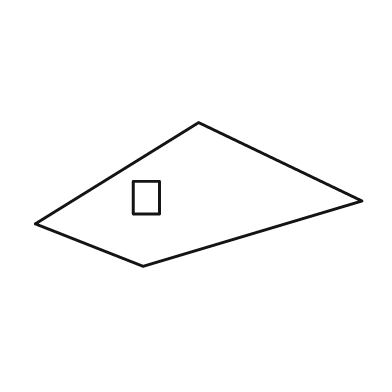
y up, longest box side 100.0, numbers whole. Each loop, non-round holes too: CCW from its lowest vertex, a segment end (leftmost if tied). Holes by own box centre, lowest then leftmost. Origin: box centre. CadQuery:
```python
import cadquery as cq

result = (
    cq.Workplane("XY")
    .moveTo(-17.0, -22.0)
    .lineTo(50.0, -2.0)
    .lineTo(0.0, 22.0)
    .lineTo(-50.0, -9.0)
    .close()
    .moveTo(-20.0, -6.0)
    .lineTo(-12.0, -6.0)
    .lineTo(-12.0, 4.0)
    .lineTo(-20.0, 4.0)
    .close()
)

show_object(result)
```